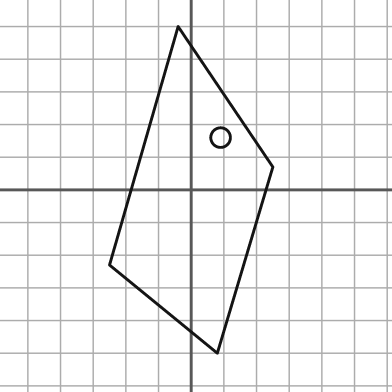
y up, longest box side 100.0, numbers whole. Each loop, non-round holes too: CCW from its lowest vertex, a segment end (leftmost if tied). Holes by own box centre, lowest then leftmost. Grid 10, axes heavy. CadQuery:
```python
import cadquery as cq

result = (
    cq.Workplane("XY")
    .moveTo(8.0, -50.0)
    .lineTo(25.0, 7.0)
    .lineTo(-4.0, 50.0)
    .lineTo(-25.0, -23.0)
    .close()
    .moveTo(9.0, 16.0)
    .circle(3.0)
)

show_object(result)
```